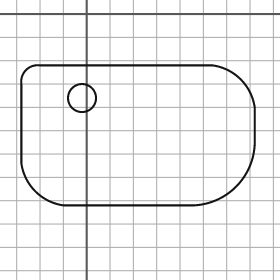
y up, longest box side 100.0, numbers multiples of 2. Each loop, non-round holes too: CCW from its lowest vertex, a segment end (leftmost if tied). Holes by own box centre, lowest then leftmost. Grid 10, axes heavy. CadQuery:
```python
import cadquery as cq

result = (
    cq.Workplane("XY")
    .moveTo(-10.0, -82.0)
    .lineTo(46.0, -82.0)
    .threePointArc((64.0, -74.0), (72.0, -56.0))
    .lineTo(72.0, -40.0)
    .threePointArc((66.0, -28.0), (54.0, -22.0))
    .lineTo(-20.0, -22.0)
    .threePointArc((-26.0, -24.0), (-28.0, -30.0))
    .lineTo(-28.0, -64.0)
    .threePointArc((-22.0, -76.0), (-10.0, -82.0))
    .close()
    .moveTo(-2.0, -36.0)
    .circle(6.0)
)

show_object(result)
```